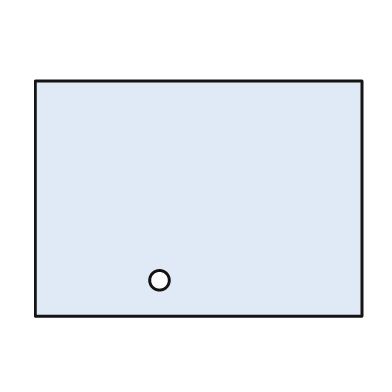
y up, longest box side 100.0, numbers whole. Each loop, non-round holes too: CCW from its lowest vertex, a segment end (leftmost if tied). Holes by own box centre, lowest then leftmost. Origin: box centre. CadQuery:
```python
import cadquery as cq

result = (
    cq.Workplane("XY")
    .moveTo(-50.0, -36.0)
    .lineTo(50.0, -36.0)
    .lineTo(50.0, 36.0)
    .lineTo(-50.0, 36.0)
    .close()
    .moveTo(-12.0, -25.0)
    .circle(3.0)
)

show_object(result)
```